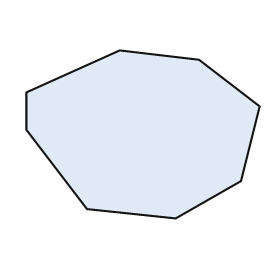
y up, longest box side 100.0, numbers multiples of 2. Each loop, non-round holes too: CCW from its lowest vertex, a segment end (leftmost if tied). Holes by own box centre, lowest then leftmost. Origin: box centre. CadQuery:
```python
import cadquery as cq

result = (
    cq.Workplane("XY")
    .moveTo(14.0, -36.0)
    .lineTo(42.0, -20.0)
    .lineTo(50.0, 12.0)
    .lineTo(24.0, 32.0)
    .lineTo(-10.0, 36.0)
    .lineTo(-50.0, 18.0)
    .lineTo(-50.0, 2.0)
    .lineTo(-24.0, -32.0)
    .close()
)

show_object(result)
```